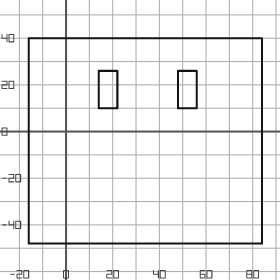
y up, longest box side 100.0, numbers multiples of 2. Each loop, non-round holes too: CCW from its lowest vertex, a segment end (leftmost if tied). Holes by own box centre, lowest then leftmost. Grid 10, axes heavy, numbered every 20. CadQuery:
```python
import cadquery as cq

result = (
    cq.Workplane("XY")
    .moveTo(-16.0, -48.0)
    .lineTo(84.0, -48.0)
    .lineTo(84.0, 40.0)
    .lineTo(-16.0, 40.0)
    .close()
    .moveTo(14.0, 10.0)
    .lineTo(22.0, 10.0)
    .lineTo(22.0, 26.0)
    .lineTo(14.0, 26.0)
    .close()
    .moveTo(48.0, 10.0)
    .lineTo(56.0, 10.0)
    .lineTo(56.0, 26.0)
    .lineTo(48.0, 26.0)
    .close()
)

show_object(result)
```